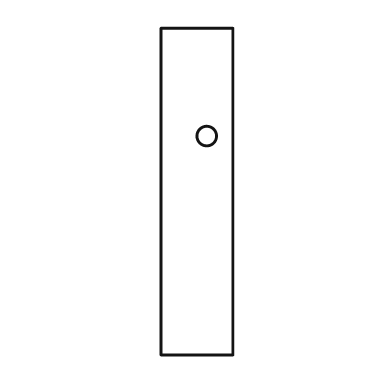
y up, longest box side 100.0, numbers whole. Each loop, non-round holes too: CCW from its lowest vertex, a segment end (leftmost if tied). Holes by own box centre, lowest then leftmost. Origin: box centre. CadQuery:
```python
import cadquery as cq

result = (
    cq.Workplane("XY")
    .moveTo(-11.0, -50.0)
    .lineTo(11.0, -50.0)
    .lineTo(11.0, 50.0)
    .lineTo(-11.0, 50.0)
    .close()
    .moveTo(3.0, 17.0)
    .circle(3.0)
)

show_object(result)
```